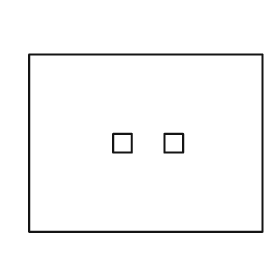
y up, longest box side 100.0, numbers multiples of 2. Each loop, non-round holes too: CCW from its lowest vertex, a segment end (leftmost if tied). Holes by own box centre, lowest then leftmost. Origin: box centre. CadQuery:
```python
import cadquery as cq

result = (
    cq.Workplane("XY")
    .moveTo(-50.0, -38.0)
    .lineTo(50.0, -38.0)
    .lineTo(50.0, 38.0)
    .lineTo(-50.0, 38.0)
    .close()
    .moveTo(-14.0, -4.0)
    .lineTo(-6.0, -4.0)
    .lineTo(-6.0, 4.0)
    .lineTo(-14.0, 4.0)
    .close()
    .moveTo(8.0, -4.0)
    .lineTo(16.0, -4.0)
    .lineTo(16.0, 4.0)
    .lineTo(8.0, 4.0)
    .close()
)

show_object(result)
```